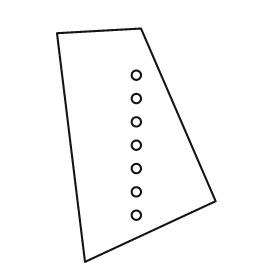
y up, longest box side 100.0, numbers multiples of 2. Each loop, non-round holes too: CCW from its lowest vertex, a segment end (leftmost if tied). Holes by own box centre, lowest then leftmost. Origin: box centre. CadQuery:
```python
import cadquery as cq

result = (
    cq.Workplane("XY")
    .moveTo(-22.0, -50.0)
    .lineTo(34.0, -24.0)
    .lineTo(2.0, 50.0)
    .lineTo(-34.0, 48.0)
    .close()
    .moveTo(0.0, -30.0)
    .circle(2.0)
    .moveTo(0.0, -20.0)
    .circle(2.0)
    .moveTo(0.0, -10.0)
    .circle(2.0)
    .moveTo(0.0, 0.0)
    .circle(2.0)
    .moveTo(0.0, 10.0)
    .circle(2.0)
    .moveTo(0.0, 20.0)
    .circle(2.0)
    .moveTo(0.0, 30.0)
    .circle(2.0)
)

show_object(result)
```